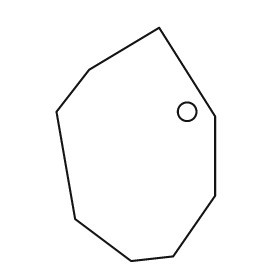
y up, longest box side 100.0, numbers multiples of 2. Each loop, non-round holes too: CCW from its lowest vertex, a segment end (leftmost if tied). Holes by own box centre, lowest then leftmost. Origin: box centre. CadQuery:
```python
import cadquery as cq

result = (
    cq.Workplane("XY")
    .moveTo(-2.0, -50.0)
    .lineTo(16.0, -48.0)
    .lineTo(34.0, -22.0)
    .lineTo(34.0, 12.0)
    .lineTo(10.0, 50.0)
    .lineTo(-20.0, 32.0)
    .lineTo(-34.0, 14.0)
    .lineTo(-26.0, -32.0)
    .close()
    .moveTo(22.0, 14.0)
    .circle(4.0)
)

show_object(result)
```